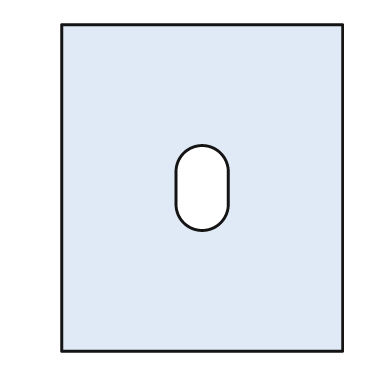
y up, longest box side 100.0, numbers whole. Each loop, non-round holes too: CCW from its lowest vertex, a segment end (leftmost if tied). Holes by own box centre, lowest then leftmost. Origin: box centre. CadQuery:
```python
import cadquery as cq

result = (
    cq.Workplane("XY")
    .moveTo(-43.0, -50.0)
    .lineTo(43.0, -50.0)
    .lineTo(43.0, 50.0)
    .lineTo(-43.0, 50.0)
    .close()
    .moveTo(-8.0, -5.0)
    .threePointArc((0.0, -13.0), (8.0, -5.0))
    .lineTo(8.0, 5.0)
    .threePointArc((0.0, 13.0), (-8.0, 5.0))
    .close()
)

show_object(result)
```